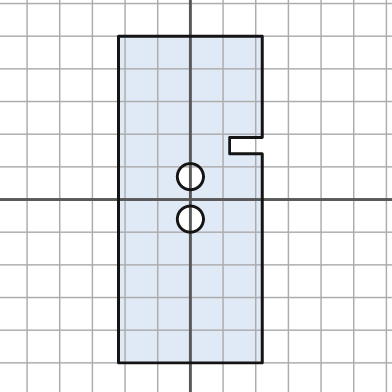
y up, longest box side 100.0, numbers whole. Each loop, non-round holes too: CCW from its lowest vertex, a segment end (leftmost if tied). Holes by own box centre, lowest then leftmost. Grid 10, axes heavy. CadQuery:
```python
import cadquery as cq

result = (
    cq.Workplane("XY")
    .moveTo(-22.0, -50.0)
    .lineTo(22.0, -50.0)
    .lineTo(22.0, 14.0)
    .lineTo(12.0, 14.0)
    .lineTo(12.0, 19.0)
    .lineTo(22.0, 19.0)
    .lineTo(22.0, 50.0)
    .lineTo(-22.0, 50.0)
    .close()
    .moveTo(0.0, -6.0)
    .circle(4.0)
    .moveTo(0.0, 7.0)
    .circle(4.0)
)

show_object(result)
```